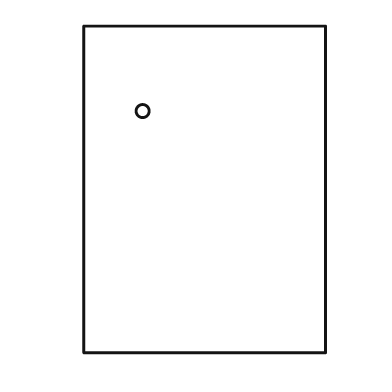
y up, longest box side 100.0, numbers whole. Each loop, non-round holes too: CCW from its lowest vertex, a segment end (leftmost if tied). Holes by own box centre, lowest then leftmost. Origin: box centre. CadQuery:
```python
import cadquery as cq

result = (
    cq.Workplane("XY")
    .moveTo(-37.0, -50.0)
    .lineTo(37.0, -50.0)
    .lineTo(37.0, 50.0)
    .lineTo(-37.0, 50.0)
    .close()
    .moveTo(-19.0, 24.0)
    .circle(2.0)
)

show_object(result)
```